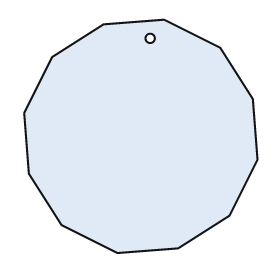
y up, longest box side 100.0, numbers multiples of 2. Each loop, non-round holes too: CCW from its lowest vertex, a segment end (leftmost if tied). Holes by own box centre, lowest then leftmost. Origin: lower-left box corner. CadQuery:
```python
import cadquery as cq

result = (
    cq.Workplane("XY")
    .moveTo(40.0, 0.0)
    .lineTo(66.0, 2.0)
    .lineTo(88.0, 16.0)
    .lineTo(100.0, 40.0)
    .lineTo(98.0, 66.0)
    .lineTo(84.0, 88.0)
    .lineTo(60.0, 100.0)
    .lineTo(34.0, 98.0)
    .lineTo(12.0, 84.0)
    .lineTo(0.0, 60.0)
    .lineTo(2.0, 34.0)
    .lineTo(16.0, 12.0)
    .close()
    .moveTo(54.0, 92.0)
    .circle(2.0)
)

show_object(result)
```